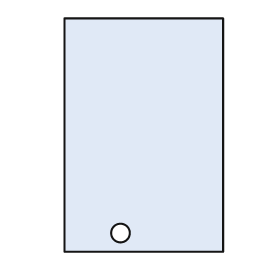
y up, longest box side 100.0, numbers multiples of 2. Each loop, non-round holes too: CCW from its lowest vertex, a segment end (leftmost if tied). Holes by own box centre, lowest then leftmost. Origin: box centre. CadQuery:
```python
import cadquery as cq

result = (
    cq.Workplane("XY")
    .moveTo(-34.0, -50.0)
    .lineTo(34.0, -50.0)
    .lineTo(34.0, 50.0)
    .lineTo(-34.0, 50.0)
    .close()
    .moveTo(-10.0, -42.0)
    .circle(4.0)
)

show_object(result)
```